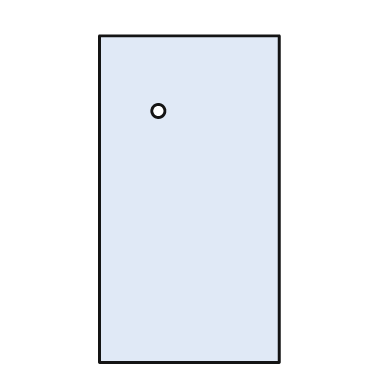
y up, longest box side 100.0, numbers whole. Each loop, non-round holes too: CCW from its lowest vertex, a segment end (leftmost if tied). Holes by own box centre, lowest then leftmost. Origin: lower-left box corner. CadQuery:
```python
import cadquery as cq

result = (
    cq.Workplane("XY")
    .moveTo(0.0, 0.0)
    .lineTo(55.0, 0.0)
    .lineTo(55.0, 100.0)
    .lineTo(0.0, 100.0)
    .close()
    .moveTo(18.0, 77.0)
    .circle(2.0)
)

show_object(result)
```